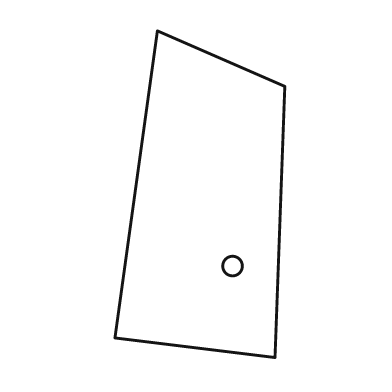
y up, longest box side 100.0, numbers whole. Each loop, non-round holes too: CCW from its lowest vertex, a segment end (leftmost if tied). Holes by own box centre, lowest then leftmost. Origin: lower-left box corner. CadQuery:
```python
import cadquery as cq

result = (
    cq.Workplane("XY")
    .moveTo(49.0, 0.0)
    .lineTo(52.0, 83.0)
    .lineTo(13.0, 100.0)
    .lineTo(0.0, 6.0)
    .close()
    .moveTo(36.0, 28.0)
    .circle(3.0)
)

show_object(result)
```